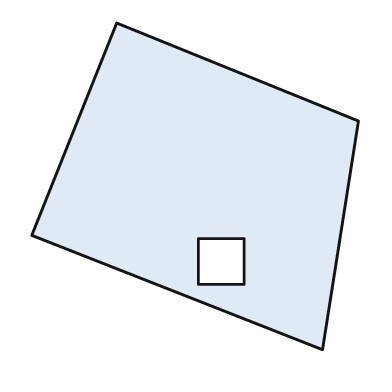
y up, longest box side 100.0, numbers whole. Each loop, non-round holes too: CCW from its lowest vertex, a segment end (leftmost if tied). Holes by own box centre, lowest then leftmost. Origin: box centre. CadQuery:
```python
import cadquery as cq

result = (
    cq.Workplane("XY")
    .moveTo(39.0, -50.0)
    .lineTo(50.0, 20.0)
    .lineTo(-24.0, 50.0)
    .lineTo(-50.0, -15.0)
    .close()
    .moveTo(1.0, -30.0)
    .lineTo(15.0, -30.0)
    .lineTo(15.0, -16.0)
    .lineTo(1.0, -16.0)
    .close()
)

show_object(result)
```